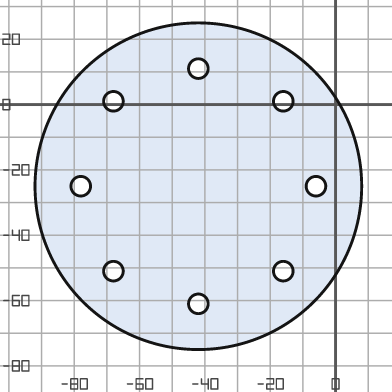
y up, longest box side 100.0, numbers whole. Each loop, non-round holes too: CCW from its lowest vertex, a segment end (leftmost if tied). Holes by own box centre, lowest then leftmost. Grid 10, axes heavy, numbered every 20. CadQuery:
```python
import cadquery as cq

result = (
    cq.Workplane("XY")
    .moveTo(-42.0, -25.0)
    .circle(50.0)
    .moveTo(-42.0, -61.0)
    .circle(3.0)
    .moveTo(-68.0, -51.0)
    .circle(3.0)
    .moveTo(-16.0, -51.0)
    .circle(3.0)
    .moveTo(-78.0, -25.0)
    .circle(3.0)
    .moveTo(-6.0, -25.0)
    .circle(3.0)
    .moveTo(-68.0, 1.0)
    .circle(3.0)
    .moveTo(-16.0, 1.0)
    .circle(3.0)
    .moveTo(-42.0, 11.0)
    .circle(3.0)
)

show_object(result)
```